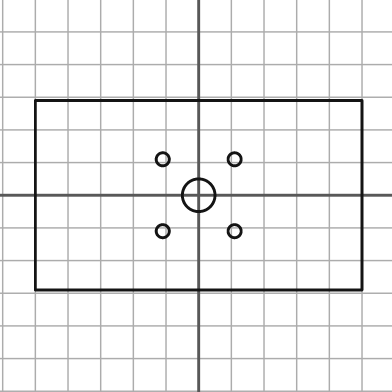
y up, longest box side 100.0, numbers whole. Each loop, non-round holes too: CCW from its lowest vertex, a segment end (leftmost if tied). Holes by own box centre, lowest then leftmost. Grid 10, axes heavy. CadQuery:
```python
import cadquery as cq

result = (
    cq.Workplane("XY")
    .moveTo(-50.0, -29.0)
    .lineTo(50.0, -29.0)
    .lineTo(50.0, 29.0)
    .lineTo(-50.0, 29.0)
    .close()
    .moveTo(-11.0, -11.0)
    .circle(2.0)
    .moveTo(11.0, -11.0)
    .circle(2.0)
    .moveTo(0.0, 0.0)
    .circle(5.0)
    .moveTo(-11.0, 11.0)
    .circle(2.0)
    .moveTo(11.0, 11.0)
    .circle(2.0)
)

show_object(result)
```